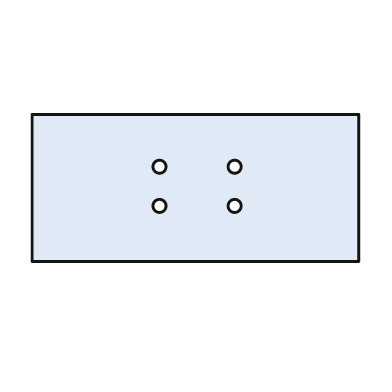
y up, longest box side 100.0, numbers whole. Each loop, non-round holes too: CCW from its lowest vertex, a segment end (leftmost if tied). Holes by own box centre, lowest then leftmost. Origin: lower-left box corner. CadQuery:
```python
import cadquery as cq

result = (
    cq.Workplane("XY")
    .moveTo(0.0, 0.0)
    .lineTo(100.0, 0.0)
    .lineTo(100.0, 45.0)
    .lineTo(0.0, 45.0)
    .close()
    .moveTo(39.0, 17.0)
    .circle(2.0)
    .moveTo(62.0, 17.0)
    .circle(2.0)
    .moveTo(39.0, 29.0)
    .circle(2.0)
    .moveTo(62.0, 29.0)
    .circle(2.0)
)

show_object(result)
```